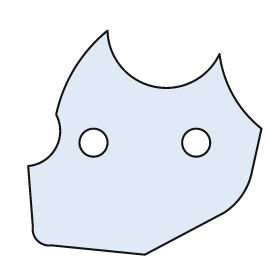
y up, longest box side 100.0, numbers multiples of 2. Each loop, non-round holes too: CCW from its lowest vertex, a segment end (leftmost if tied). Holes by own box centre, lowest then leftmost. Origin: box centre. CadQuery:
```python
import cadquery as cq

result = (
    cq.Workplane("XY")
    .moveTo(0.0, -48.0)
    .lineTo(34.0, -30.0)
    .threePointArc((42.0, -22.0), (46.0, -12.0))
    .lineTo(50.0, 6.0)
    .threePointArc((38.0, 20.0), (32.0, 38.0))
    .threePointArc((4.0, 24.0), (-16.0, 48.0))
    .threePointArc((-30.0, 32.0), (-38.0, 12.0))
    .threePointArc((-38.0, -2.0), (-50.0, -10.0))
    .lineTo(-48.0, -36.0)
    .threePointArc((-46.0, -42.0), (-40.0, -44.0))
    .close()
    .moveTo(-22.0, 0.0)
    .circle(6.0)
    .moveTo(22.0, 0.0)
    .circle(6.0)
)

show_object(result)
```